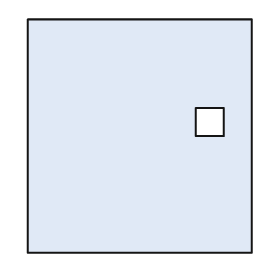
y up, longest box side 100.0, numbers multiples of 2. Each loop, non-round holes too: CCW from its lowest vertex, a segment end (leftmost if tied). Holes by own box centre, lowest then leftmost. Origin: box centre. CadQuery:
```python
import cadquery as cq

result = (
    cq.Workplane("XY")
    .moveTo(-48.0, -50.0)
    .lineTo(48.0, -50.0)
    .lineTo(48.0, 50.0)
    .lineTo(-48.0, 50.0)
    .close()
    .moveTo(24.0, 0.0)
    .lineTo(36.0, 0.0)
    .lineTo(36.0, 12.0)
    .lineTo(24.0, 12.0)
    .close()
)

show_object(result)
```